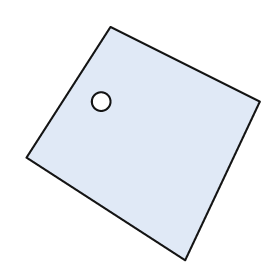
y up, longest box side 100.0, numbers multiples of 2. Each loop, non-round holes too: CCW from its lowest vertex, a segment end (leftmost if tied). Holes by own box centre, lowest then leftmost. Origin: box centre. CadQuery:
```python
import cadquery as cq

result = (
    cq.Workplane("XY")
    .moveTo(18.0, -50.0)
    .lineTo(50.0, 18.0)
    .lineTo(-14.0, 50.0)
    .lineTo(-50.0, -6.0)
    .close()
    .moveTo(-18.0, 18.0)
    .circle(4.0)
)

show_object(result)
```